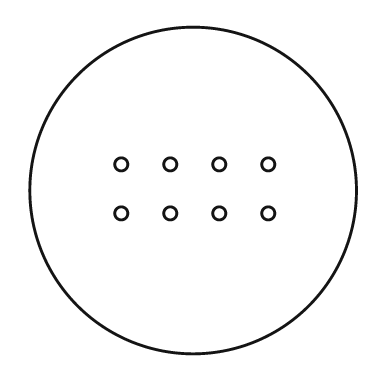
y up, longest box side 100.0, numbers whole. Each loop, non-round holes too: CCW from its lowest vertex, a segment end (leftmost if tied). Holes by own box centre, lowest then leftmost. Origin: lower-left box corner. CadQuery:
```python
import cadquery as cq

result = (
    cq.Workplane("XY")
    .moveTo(50.0, 50.0)
    .circle(50.0)
    .moveTo(28.0, 43.0)
    .circle(2.0)
    .moveTo(43.0, 43.0)
    .circle(2.0)
    .moveTo(58.0, 43.0)
    .circle(2.0)
    .moveTo(73.0, 43.0)
    .circle(2.0)
    .moveTo(28.0, 58.0)
    .circle(2.0)
    .moveTo(43.0, 58.0)
    .circle(2.0)
    .moveTo(58.0, 58.0)
    .circle(2.0)
    .moveTo(73.0, 58.0)
    .circle(2.0)
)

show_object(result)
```